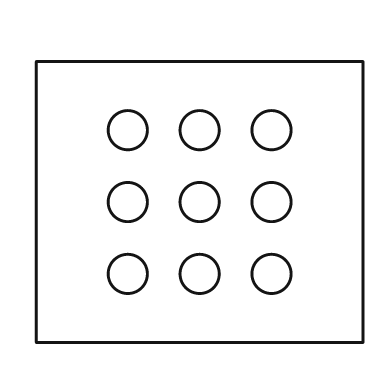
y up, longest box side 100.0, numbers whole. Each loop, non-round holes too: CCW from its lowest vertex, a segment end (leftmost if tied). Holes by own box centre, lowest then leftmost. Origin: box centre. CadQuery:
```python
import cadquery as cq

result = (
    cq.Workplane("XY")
    .moveTo(-50.0, -43.0)
    .lineTo(50.0, -43.0)
    .lineTo(50.0, 43.0)
    .lineTo(-50.0, 43.0)
    .close()
    .moveTo(-22.0, -22.0)
    .circle(6.0)
    .moveTo(0.0, -22.0)
    .circle(6.0)
    .moveTo(22.0, -22.0)
    .circle(6.0)
    .moveTo(-22.0, 0.0)
    .circle(6.0)
    .moveTo(0.0, 0.0)
    .circle(6.0)
    .moveTo(22.0, 0.0)
    .circle(6.0)
    .moveTo(-22.0, 22.0)
    .circle(6.0)
    .moveTo(0.0, 22.0)
    .circle(6.0)
    .moveTo(22.0, 22.0)
    .circle(6.0)
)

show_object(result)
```